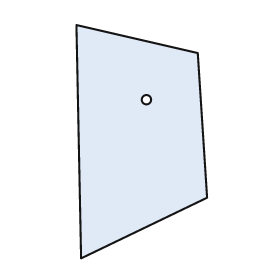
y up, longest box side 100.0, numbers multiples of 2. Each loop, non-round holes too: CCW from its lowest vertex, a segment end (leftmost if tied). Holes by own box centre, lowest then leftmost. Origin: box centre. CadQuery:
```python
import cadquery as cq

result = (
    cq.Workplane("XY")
    .moveTo(-26.0, -50.0)
    .lineTo(28.0, -24.0)
    .lineTo(24.0, 38.0)
    .lineTo(-28.0, 50.0)
    .close()
    .moveTo(2.0, 18.0)
    .circle(2.0)
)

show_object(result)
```